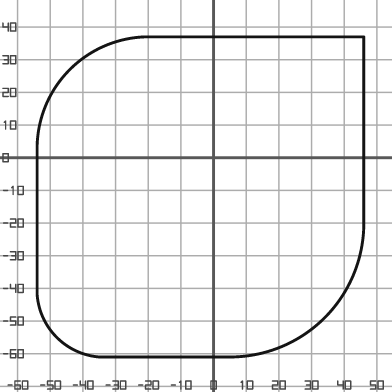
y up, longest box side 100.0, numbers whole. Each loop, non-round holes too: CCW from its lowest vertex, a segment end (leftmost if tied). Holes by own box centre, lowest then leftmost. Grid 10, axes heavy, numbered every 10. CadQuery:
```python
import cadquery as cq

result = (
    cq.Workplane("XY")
    .moveTo(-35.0, -61.0)
    .lineTo(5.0, -61.0)
    .threePointArc((34.0, -49.0), (46.0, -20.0))
    .lineTo(46.0, 37.0)
    .lineTo(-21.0, 37.0)
    .threePointArc((-44.0, 27.0), (-54.0, 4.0))
    .lineTo(-54.0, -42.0)
    .threePointArc((-48.0, -55.0), (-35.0, -61.0))
    .close()
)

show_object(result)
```